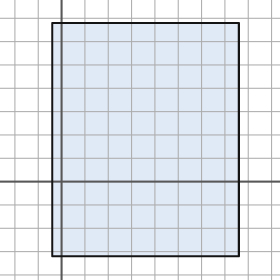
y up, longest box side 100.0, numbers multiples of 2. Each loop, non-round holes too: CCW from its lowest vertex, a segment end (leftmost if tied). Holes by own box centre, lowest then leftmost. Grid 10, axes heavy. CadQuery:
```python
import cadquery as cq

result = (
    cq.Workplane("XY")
    .moveTo(-4.0, -32.0)
    .lineTo(76.0, -32.0)
    .lineTo(76.0, 68.0)
    .lineTo(-4.0, 68.0)
    .close()
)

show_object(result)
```